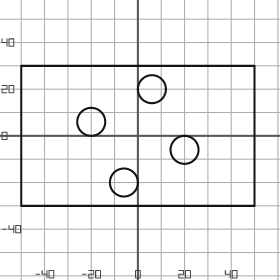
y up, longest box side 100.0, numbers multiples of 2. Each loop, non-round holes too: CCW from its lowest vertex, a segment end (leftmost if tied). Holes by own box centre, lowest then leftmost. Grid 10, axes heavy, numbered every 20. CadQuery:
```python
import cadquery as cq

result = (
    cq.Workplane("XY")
    .moveTo(-50.0, -30.0)
    .lineTo(50.0, -30.0)
    .lineTo(50.0, 30.0)
    .lineTo(-50.0, 30.0)
    .close()
    .moveTo(-6.0, -20.0)
    .circle(6.0)
    .moveTo(20.0, -6.0)
    .circle(6.0)
    .moveTo(-20.0, 6.0)
    .circle(6.0)
    .moveTo(6.0, 20.0)
    .circle(6.0)
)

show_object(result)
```